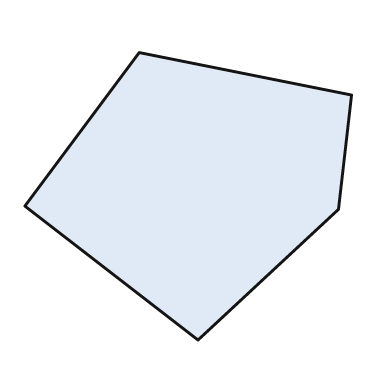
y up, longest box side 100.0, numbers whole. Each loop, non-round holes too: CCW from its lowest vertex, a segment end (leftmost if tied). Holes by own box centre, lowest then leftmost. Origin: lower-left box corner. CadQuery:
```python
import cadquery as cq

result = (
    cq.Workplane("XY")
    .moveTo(53.0, 0.0)
    .lineTo(96.0, 40.0)
    .lineTo(100.0, 75.0)
    .lineTo(35.0, 88.0)
    .lineTo(0.0, 41.0)
    .close()
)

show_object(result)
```